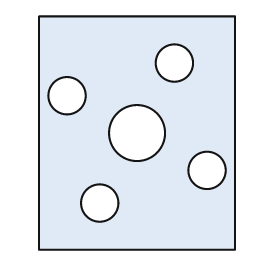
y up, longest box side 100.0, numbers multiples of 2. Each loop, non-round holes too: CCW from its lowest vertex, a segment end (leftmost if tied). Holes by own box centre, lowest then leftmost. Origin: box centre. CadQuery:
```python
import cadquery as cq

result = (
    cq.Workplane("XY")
    .moveTo(-42.0, -50.0)
    .lineTo(42.0, -50.0)
    .lineTo(42.0, 50.0)
    .lineTo(-42.0, 50.0)
    .close()
    .moveTo(-16.0, -30.0)
    .circle(8.0)
    .moveTo(30.0, -16.0)
    .circle(8.0)
    .moveTo(0.0, 0.0)
    .circle(12.0)
    .moveTo(-30.0, 16.0)
    .circle(8.0)
    .moveTo(16.0, 30.0)
    .circle(8.0)
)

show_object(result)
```